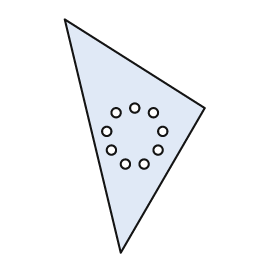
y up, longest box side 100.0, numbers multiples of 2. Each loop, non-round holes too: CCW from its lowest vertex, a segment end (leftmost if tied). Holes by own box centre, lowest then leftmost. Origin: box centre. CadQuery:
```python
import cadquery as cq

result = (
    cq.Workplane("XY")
    .moveTo(-6.0, -50.0)
    .lineTo(30.0, 12.0)
    .lineTo(-30.0, 50.0)
    .close()
    .moveTo(-4.0, -12.0)
    .circle(2.0)
    .moveTo(4.0, -12.0)
    .circle(2.0)
    .moveTo(-10.0, -6.0)
    .circle(2.0)
    .moveTo(10.0, -6.0)
    .circle(2.0)
    .moveTo(-12.0, 2.0)
    .circle(2.0)
    .moveTo(12.0, 2.0)
    .circle(2.0)
    .moveTo(-8.0, 10.0)
    .circle(2.0)
    .moveTo(8.0, 10.0)
    .circle(2.0)
    .moveTo(0.0, 12.0)
    .circle(2.0)
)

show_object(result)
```